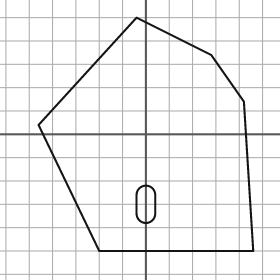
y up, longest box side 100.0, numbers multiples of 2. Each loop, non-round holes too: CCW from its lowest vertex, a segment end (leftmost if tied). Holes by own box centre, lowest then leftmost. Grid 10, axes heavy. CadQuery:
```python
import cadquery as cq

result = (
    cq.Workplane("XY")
    .moveTo(-20.0, -50.0)
    .lineTo(46.0, -50.0)
    .lineTo(42.0, 14.0)
    .lineTo(28.0, 34.0)
    .lineTo(-4.0, 50.0)
    .lineTo(-46.0, 4.0)
    .close()
    .moveTo(-4.0, -34.0)
    .threePointArc((0.0, -38.0), (4.0, -34.0))
    .lineTo(4.0, -26.0)
    .threePointArc((0.0, -22.0), (-4.0, -26.0))
    .close()
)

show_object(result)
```